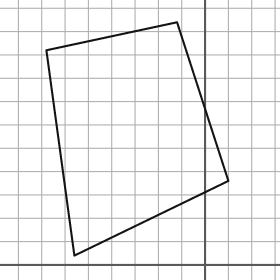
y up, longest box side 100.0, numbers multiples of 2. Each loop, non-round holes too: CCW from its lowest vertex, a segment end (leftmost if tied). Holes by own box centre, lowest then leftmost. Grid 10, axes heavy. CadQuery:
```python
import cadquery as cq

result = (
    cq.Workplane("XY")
    .moveTo(-56.0, 4.0)
    .lineTo(10.0, 36.0)
    .lineTo(-12.0, 104.0)
    .lineTo(-68.0, 92.0)
    .close()
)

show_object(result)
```